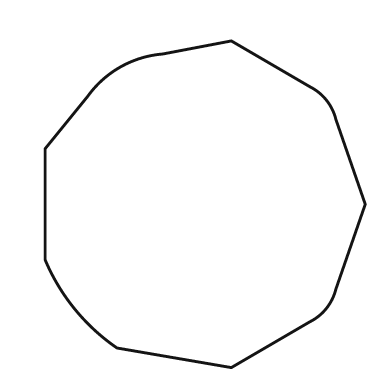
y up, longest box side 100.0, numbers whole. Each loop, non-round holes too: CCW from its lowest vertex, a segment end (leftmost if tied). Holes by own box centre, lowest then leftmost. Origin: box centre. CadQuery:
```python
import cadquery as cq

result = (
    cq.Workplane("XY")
    .moveTo(8.0, -50.0)
    .lineTo(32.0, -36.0)
    .threePointArc((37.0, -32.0), (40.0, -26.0))
    .lineTo(49.0, 0.0)
    .lineTo(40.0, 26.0)
    .threePointArc((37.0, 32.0), (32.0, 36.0))
    .lineTo(8.0, 50.0)
    .lineTo(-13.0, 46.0)
    .threePointArc((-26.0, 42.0), (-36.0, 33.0))
    .lineTo(-49.0, 17.0)
    .lineTo(-49.0, -17.0)
    .threePointArc((-40.0, -32.0), (-27.0, -44.0))
    .close()
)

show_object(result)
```